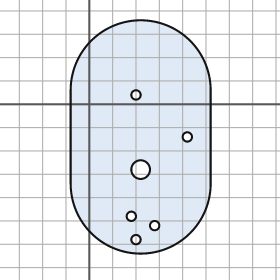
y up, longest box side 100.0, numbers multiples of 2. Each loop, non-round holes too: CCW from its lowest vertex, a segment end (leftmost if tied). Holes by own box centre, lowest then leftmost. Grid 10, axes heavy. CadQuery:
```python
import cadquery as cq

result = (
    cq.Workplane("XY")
    .moveTo(-8.0, -34.0)
    .threePointArc((22.0, -64.0), (52.0, -34.0))
    .lineTo(52.0, 6.0)
    .threePointArc((22.0, 36.0), (-8.0, 6.0))
    .close()
    .moveTo(20.0, -58.0)
    .circle(2.0)
    .moveTo(28.0, -52.0)
    .circle(2.0)
    .moveTo(18.0, -48.0)
    .circle(2.0)
    .moveTo(22.0, -28.0)
    .circle(4.0)
    .moveTo(42.0, -14.0)
    .circle(2.0)
    .moveTo(20.0, 4.0)
    .circle(2.0)
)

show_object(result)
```